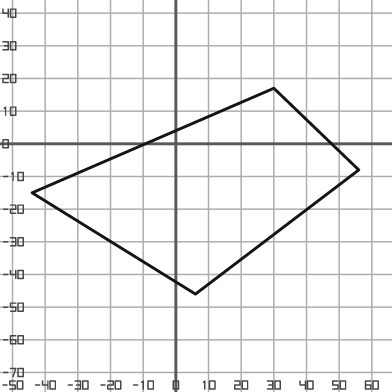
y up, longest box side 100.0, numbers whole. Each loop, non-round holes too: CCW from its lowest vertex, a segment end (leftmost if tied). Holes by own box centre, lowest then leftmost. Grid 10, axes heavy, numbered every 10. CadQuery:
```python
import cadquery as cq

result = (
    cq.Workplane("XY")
    .moveTo(6.0, -46.0)
    .lineTo(56.0, -8.0)
    .lineTo(30.0, 17.0)
    .lineTo(-44.0, -15.0)
    .close()
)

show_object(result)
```